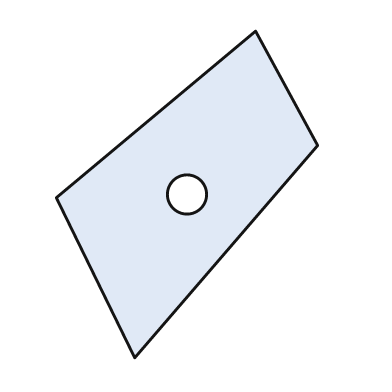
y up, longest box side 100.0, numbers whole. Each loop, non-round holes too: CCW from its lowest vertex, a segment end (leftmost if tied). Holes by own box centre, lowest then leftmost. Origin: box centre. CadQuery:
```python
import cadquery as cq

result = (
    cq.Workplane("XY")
    .moveTo(-16.0, -50.0)
    .lineTo(40.0, 15.0)
    .lineTo(21.0, 50.0)
    .lineTo(-40.0, -1.0)
    .close()
    .moveTo(0.0, 0.0)
    .circle(6.0)
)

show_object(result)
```